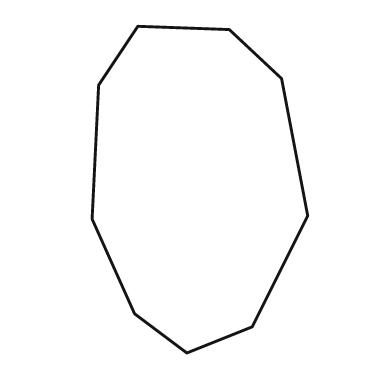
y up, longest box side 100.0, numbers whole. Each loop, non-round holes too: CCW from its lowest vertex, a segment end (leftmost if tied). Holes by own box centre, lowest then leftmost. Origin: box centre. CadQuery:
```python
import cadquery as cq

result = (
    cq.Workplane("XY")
    .moveTo(-4.0, -50.0)
    .lineTo(16.0, -42.0)
    .lineTo(33.0, -8.0)
    .lineTo(25.0, 34.0)
    .lineTo(9.0, 49.0)
    .lineTo(-19.0, 50.0)
    .lineTo(-31.0, 32.0)
    .lineTo(-33.0, -9.0)
    .lineTo(-20.0, -38.0)
    .close()
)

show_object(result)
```